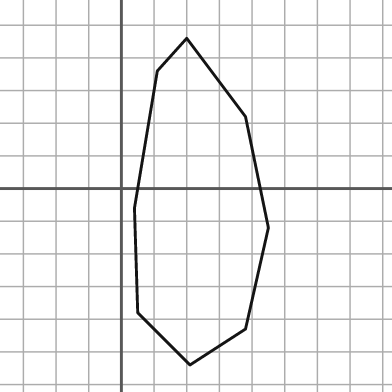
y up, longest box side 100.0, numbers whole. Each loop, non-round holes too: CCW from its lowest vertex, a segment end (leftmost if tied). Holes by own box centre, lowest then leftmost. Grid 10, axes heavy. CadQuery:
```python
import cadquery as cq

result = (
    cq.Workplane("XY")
    .moveTo(21.0, -54.0)
    .lineTo(38.0, -43.0)
    .lineTo(45.0, -12.0)
    .lineTo(38.0, 22.0)
    .lineTo(20.0, 46.0)
    .lineTo(11.0, 36.0)
    .lineTo(4.0, -6.0)
    .lineTo(5.0, -38.0)
    .close()
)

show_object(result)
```